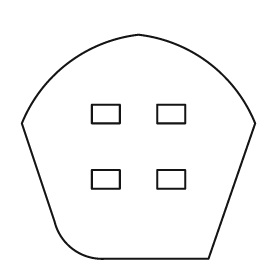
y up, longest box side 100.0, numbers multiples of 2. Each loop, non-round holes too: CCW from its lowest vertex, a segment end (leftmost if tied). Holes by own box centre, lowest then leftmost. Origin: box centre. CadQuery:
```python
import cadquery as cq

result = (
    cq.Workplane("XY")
    .moveTo(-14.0, -48.0)
    .lineTo(30.0, -48.0)
    .lineTo(50.0, 10.0)
    .threePointArc((30.0, 36.0), (0.0, 48.0))
    .threePointArc((-30.0, 36.0), (-50.0, 10.0))
    .lineTo(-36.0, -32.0)
    .threePointArc((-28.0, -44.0), (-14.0, -48.0))
    .close()
    .moveTo(-20.0, -18.0)
    .lineTo(-8.0, -18.0)
    .lineTo(-8.0, -10.0)
    .lineTo(-20.0, -10.0)
    .close()
    .moveTo(8.0, -18.0)
    .lineTo(20.0, -18.0)
    .lineTo(20.0, -10.0)
    .lineTo(8.0, -10.0)
    .close()
    .moveTo(-20.0, 10.0)
    .lineTo(-8.0, 10.0)
    .lineTo(-8.0, 18.0)
    .lineTo(-20.0, 18.0)
    .close()
    .moveTo(8.0, 10.0)
    .lineTo(20.0, 10.0)
    .lineTo(20.0, 18.0)
    .lineTo(8.0, 18.0)
    .close()
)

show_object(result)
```